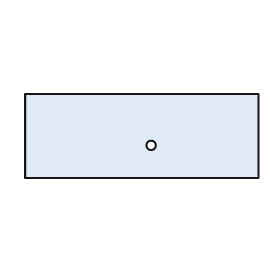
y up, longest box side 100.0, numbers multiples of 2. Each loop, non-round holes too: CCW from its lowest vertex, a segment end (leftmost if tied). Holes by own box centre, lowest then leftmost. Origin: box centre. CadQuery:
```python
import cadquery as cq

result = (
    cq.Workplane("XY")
    .moveTo(-50.0, -18.0)
    .lineTo(50.0, -18.0)
    .lineTo(50.0, 18.0)
    .lineTo(-50.0, 18.0)
    .close()
    .moveTo(4.0, -4.0)
    .circle(2.0)
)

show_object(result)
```